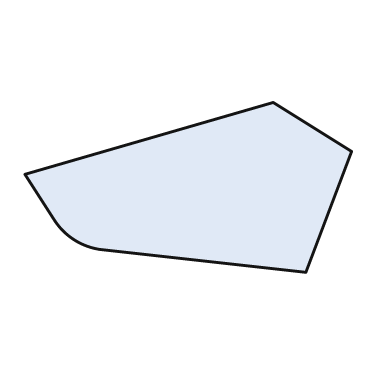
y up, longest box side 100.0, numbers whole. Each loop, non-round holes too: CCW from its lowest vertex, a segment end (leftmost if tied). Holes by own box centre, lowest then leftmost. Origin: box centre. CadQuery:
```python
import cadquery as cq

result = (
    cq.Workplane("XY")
    .moveTo(36.0, -26.0)
    .lineTo(50.0, 11.0)
    .lineTo(26.0, 26.0)
    .lineTo(-50.0, 4.0)
    .lineTo(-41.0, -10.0)
    .threePointArc((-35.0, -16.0), (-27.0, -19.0))
    .close()
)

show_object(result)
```